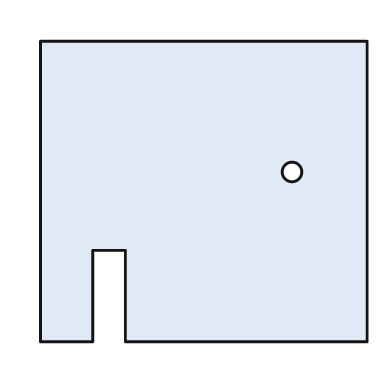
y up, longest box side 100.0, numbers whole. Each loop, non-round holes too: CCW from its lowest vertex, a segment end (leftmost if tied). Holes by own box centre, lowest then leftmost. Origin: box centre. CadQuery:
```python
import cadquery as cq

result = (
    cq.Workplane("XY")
    .moveTo(-50.0, -46.0)
    .lineTo(-34.0, -46.0)
    .lineTo(-34.0, -18.0)
    .lineTo(-24.0, -18.0)
    .lineTo(-24.0, -46.0)
    .lineTo(50.0, -46.0)
    .lineTo(50.0, 46.0)
    .lineTo(-50.0, 46.0)
    .close()
    .moveTo(27.0, 6.0)
    .circle(3.0)
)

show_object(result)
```